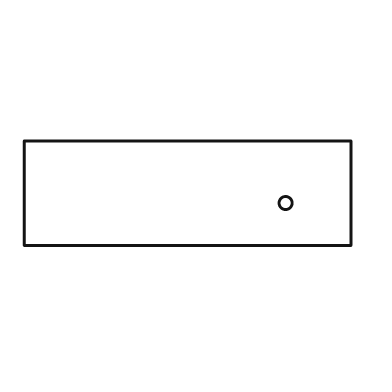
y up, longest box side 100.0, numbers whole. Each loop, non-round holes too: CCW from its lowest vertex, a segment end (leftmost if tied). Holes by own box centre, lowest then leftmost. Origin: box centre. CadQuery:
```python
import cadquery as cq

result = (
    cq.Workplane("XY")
    .moveTo(-50.0, -16.0)
    .lineTo(50.0, -16.0)
    .lineTo(50.0, 16.0)
    .lineTo(-50.0, 16.0)
    .close()
    .moveTo(30.0, -3.0)
    .circle(2.0)
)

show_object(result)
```